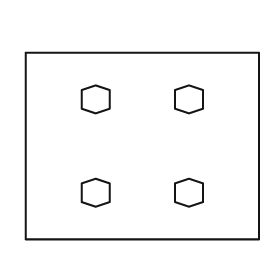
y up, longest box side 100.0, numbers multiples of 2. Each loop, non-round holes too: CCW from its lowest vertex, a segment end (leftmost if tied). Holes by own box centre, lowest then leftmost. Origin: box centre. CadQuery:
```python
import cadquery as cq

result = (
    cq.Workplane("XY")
    .moveTo(-50.0, -40.0)
    .lineTo(50.0, -40.0)
    .lineTo(50.0, 40.0)
    .lineTo(-50.0, 40.0)
    .close()
    .moveTo(-20.0, -26.0)
    .lineTo(-14.0, -24.0)
    .lineTo(-14.0, -16.0)
    .lineTo(-20.0, -14.0)
    .lineTo(-26.0, -16.0)
    .lineTo(-26.0, -24.0)
    .close()
    .moveTo(20.0, -26.0)
    .lineTo(26.0, -24.0)
    .lineTo(26.0, -16.0)
    .lineTo(20.0, -14.0)
    .lineTo(14.0, -16.0)
    .lineTo(14.0, -24.0)
    .close()
    .moveTo(-20.0, 14.0)
    .lineTo(-14.0, 16.0)
    .lineTo(-14.0, 24.0)
    .lineTo(-20.0, 26.0)
    .lineTo(-26.0, 24.0)
    .lineTo(-26.0, 16.0)
    .close()
    .moveTo(20.0, 14.0)
    .lineTo(26.0, 16.0)
    .lineTo(26.0, 24.0)
    .lineTo(20.0, 26.0)
    .lineTo(14.0, 24.0)
    .lineTo(14.0, 16.0)
    .close()
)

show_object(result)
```